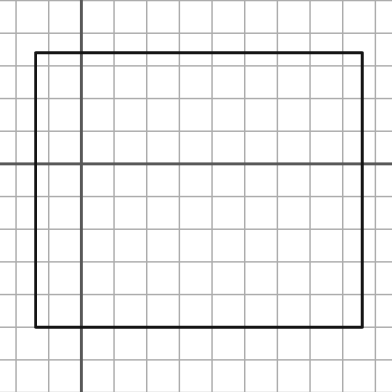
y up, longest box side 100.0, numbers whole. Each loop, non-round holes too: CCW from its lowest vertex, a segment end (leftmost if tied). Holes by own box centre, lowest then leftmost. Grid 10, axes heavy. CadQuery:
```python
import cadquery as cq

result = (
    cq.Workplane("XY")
    .moveTo(-14.0, -50.0)
    .lineTo(86.0, -50.0)
    .lineTo(86.0, 34.0)
    .lineTo(-14.0, 34.0)
    .close()
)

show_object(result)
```